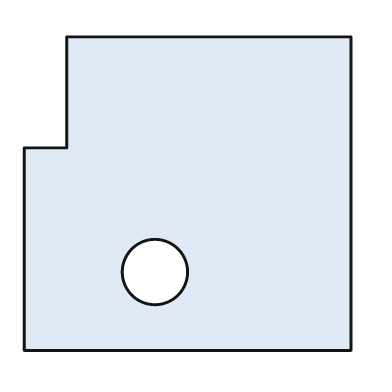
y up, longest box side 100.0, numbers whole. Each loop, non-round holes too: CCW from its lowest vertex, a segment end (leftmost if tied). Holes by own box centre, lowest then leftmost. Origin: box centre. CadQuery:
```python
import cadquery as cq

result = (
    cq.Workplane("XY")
    .moveTo(-50.0, -48.0)
    .lineTo(50.0, -48.0)
    .lineTo(50.0, 48.0)
    .lineTo(-37.0, 48.0)
    .lineTo(-37.0, 14.0)
    .lineTo(-50.0, 14.0)
    .close()
    .moveTo(-10.0, -24.0)
    .circle(10.0)
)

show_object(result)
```